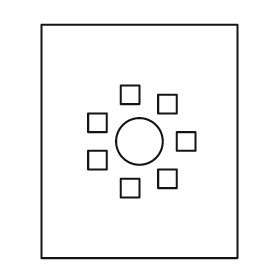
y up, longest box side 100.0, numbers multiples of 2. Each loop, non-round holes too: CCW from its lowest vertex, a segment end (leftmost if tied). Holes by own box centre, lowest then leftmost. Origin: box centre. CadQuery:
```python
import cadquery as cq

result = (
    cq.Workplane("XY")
    .moveTo(-42.0, -50.0)
    .lineTo(42.0, -50.0)
    .lineTo(42.0, 50.0)
    .lineTo(-42.0, 50.0)
    .close()
    .moveTo(-8.0, -24.0)
    .lineTo(0.0, -24.0)
    .lineTo(0.0, -16.0)
    .lineTo(-8.0, -16.0)
    .close()
    .moveTo(8.0, -20.0)
    .lineTo(16.0, -20.0)
    .lineTo(16.0, -12.0)
    .lineTo(8.0, -12.0)
    .close()
    .moveTo(-22.0, -12.0)
    .lineTo(-14.0, -12.0)
    .lineTo(-14.0, -4.0)
    .lineTo(-22.0, -4.0)
    .close()
    .moveTo(0.0, 0.0)
    .circle(10.0)
    .moveTo(16.0, -4.0)
    .lineTo(24.0, -4.0)
    .lineTo(24.0, 4.0)
    .lineTo(16.0, 4.0)
    .close()
    .moveTo(-22.0, 4.0)
    .lineTo(-14.0, 4.0)
    .lineTo(-14.0, 12.0)
    .lineTo(-22.0, 12.0)
    .close()
    .moveTo(8.0, 12.0)
    .lineTo(16.0, 12.0)
    .lineTo(16.0, 20.0)
    .lineTo(8.0, 20.0)
    .close()
    .moveTo(-8.0, 16.0)
    .lineTo(0.0, 16.0)
    .lineTo(0.0, 24.0)
    .lineTo(-8.0, 24.0)
    .close()
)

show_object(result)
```